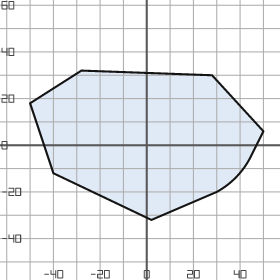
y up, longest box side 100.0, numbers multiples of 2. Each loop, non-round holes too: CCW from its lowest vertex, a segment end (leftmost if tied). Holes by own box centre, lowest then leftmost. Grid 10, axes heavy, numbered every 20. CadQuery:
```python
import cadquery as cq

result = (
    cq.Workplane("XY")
    .moveTo(2.0, -32.0)
    .lineTo(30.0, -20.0)
    .threePointArc((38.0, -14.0), (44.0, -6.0))
    .lineTo(50.0, 6.0)
    .lineTo(28.0, 30.0)
    .lineTo(-28.0, 32.0)
    .lineTo(-50.0, 18.0)
    .lineTo(-40.0, -12.0)
    .close()
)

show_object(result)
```